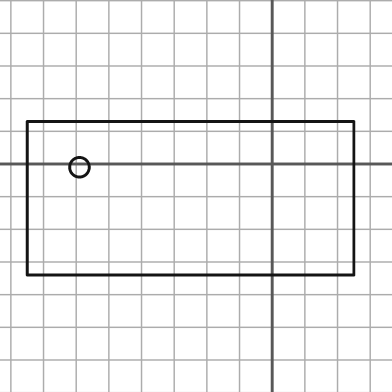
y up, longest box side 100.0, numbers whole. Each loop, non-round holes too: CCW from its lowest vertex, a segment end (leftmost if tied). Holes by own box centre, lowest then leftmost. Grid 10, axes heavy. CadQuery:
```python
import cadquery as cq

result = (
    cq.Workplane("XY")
    .moveTo(-75.0, -34.0)
    .lineTo(25.0, -34.0)
    .lineTo(25.0, 13.0)
    .lineTo(-75.0, 13.0)
    .close()
    .moveTo(-59.0, -1.0)
    .circle(3.0)
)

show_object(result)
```